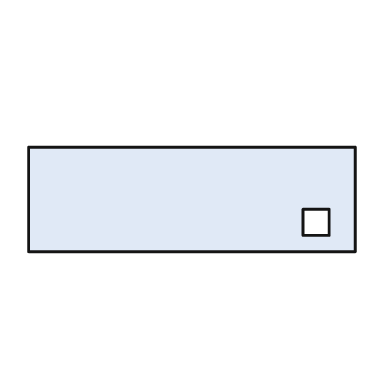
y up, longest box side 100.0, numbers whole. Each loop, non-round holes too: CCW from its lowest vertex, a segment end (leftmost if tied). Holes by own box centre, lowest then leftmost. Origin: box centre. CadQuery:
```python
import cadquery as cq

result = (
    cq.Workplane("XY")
    .moveTo(-50.0, -16.0)
    .lineTo(50.0, -16.0)
    .lineTo(50.0, 16.0)
    .lineTo(-50.0, 16.0)
    .close()
    .moveTo(34.0, -11.0)
    .lineTo(42.0, -11.0)
    .lineTo(42.0, -3.0)
    .lineTo(34.0, -3.0)
    .close()
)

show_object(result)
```